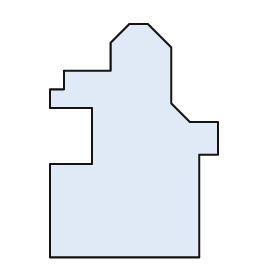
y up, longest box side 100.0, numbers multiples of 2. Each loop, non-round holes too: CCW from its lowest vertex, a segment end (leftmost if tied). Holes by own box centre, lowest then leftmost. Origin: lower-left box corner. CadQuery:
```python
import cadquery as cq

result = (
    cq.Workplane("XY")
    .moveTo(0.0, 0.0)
    .lineTo(64.0, 0.0)
    .lineTo(64.0, 44.0)
    .lineTo(72.0, 44.0)
    .lineTo(72.0, 58.0)
    .lineTo(60.0, 58.0)
    .lineTo(52.0, 66.0)
    .lineTo(52.0, 90.0)
    .lineTo(42.0, 100.0)
    .lineTo(34.0, 100.0)
    .lineTo(26.0, 92.0)
    .lineTo(26.0, 80.0)
    .lineTo(6.0, 80.0)
    .lineTo(6.0, 72.0)
    .lineTo(0.0, 72.0)
    .lineTo(0.0, 64.0)
    .lineTo(18.0, 64.0)
    .lineTo(18.0, 40.0)
    .lineTo(0.0, 40.0)
    .close()
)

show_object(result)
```